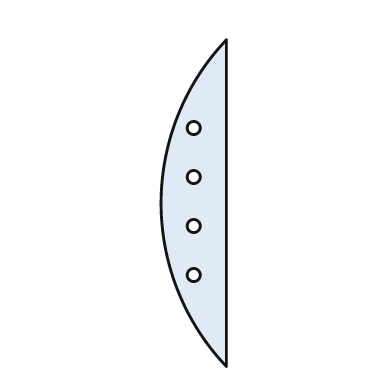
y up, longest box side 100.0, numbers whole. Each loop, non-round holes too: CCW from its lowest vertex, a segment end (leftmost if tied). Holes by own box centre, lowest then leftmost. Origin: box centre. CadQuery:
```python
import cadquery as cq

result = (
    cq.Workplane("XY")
    .moveTo(10.0, -50.0)
    .lineTo(10.0, 50.0)
    .threePointArc((-10.0, 0.0), (10.0, -50.0))
    .close()
    .moveTo(0.0, -22.0)
    .circle(2.0)
    .moveTo(0.0, -7.0)
    .circle(2.0)
    .moveTo(0.0, 8.0)
    .circle(2.0)
    .moveTo(0.0, 23.0)
    .circle(2.0)
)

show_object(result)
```